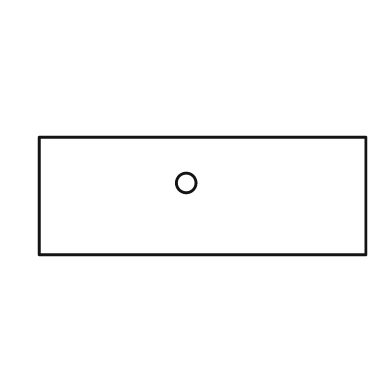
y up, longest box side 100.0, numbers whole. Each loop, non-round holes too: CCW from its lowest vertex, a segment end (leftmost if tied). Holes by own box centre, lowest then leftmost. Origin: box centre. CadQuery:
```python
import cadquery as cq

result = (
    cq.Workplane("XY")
    .moveTo(-50.0, -18.0)
    .lineTo(50.0, -18.0)
    .lineTo(50.0, 18.0)
    .lineTo(-50.0, 18.0)
    .close()
    .moveTo(-5.0, 4.0)
    .circle(3.0)
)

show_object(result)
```